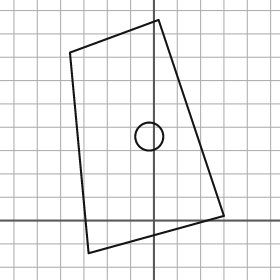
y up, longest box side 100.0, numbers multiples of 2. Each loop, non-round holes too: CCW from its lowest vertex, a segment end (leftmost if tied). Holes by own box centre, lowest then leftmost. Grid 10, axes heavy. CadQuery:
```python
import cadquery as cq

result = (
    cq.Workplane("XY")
    .moveTo(-28.0, -14.0)
    .lineTo(30.0, 2.0)
    .lineTo(2.0, 86.0)
    .lineTo(-36.0, 72.0)
    .close()
    .moveTo(-2.0, 36.0)
    .circle(6.0)
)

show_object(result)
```